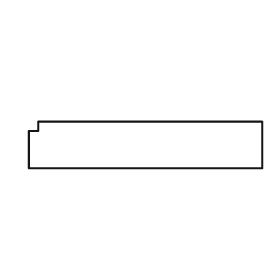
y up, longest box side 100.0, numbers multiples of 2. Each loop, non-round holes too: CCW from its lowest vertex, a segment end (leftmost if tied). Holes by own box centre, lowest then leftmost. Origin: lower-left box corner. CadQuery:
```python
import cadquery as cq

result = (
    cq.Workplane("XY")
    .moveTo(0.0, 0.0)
    .lineTo(100.0, 0.0)
    .lineTo(100.0, 20.0)
    .lineTo(4.0, 20.0)
    .lineTo(4.0, 16.0)
    .lineTo(0.0, 16.0)
    .close()
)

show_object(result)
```